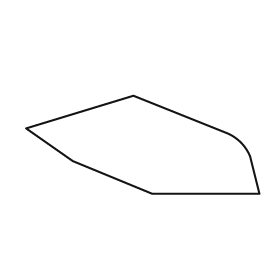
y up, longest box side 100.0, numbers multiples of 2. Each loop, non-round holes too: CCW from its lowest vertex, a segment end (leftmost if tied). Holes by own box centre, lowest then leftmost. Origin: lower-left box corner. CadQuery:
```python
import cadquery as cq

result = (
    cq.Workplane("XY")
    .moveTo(54.0, 0.0)
    .lineTo(100.0, 0.0)
    .lineTo(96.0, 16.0)
    .threePointArc((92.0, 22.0), (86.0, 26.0))
    .lineTo(46.0, 42.0)
    .lineTo(0.0, 28.0)
    .lineTo(20.0, 14.0)
    .close()
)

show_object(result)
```